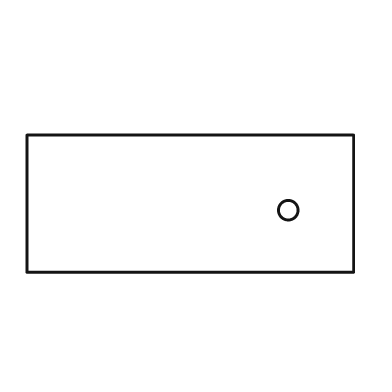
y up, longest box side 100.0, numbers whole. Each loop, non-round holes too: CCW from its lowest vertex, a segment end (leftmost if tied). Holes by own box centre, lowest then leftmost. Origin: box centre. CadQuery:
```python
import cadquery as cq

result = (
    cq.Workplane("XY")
    .moveTo(-50.0, -21.0)
    .lineTo(50.0, -21.0)
    .lineTo(50.0, 21.0)
    .lineTo(-50.0, 21.0)
    .close()
    .moveTo(30.0, -2.0)
    .circle(3.0)
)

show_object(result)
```